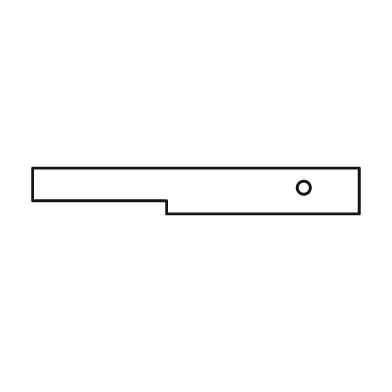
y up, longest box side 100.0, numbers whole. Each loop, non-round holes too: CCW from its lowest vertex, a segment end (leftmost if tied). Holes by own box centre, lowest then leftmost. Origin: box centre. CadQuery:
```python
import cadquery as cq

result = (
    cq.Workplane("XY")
    .moveTo(-9.0, -7.0)
    .lineTo(50.0, -7.0)
    .lineTo(50.0, 7.0)
    .lineTo(-50.0, 7.0)
    .lineTo(-50.0, -3.0)
    .lineTo(-9.0, -3.0)
    .close()
    .moveTo(33.0, 1.0)
    .circle(2.0)
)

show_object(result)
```